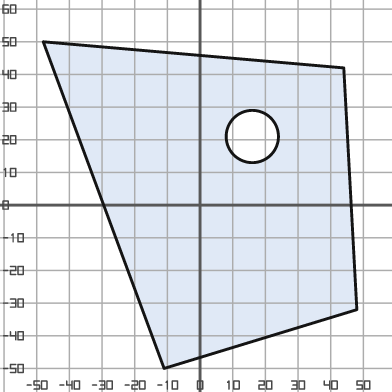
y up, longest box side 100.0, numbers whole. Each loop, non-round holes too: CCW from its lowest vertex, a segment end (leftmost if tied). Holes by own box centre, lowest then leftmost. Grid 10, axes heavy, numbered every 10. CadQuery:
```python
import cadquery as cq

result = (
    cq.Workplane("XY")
    .moveTo(-11.0, -50.0)
    .lineTo(48.0, -32.0)
    .lineTo(44.0, 42.0)
    .lineTo(-48.0, 50.0)
    .close()
    .moveTo(16.0, 21.0)
    .circle(8.0)
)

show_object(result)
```